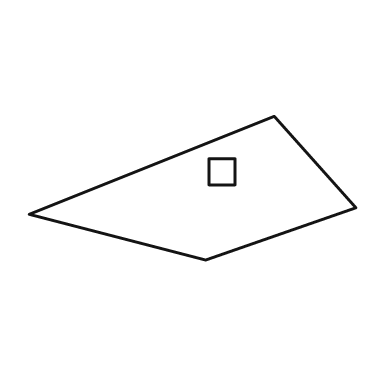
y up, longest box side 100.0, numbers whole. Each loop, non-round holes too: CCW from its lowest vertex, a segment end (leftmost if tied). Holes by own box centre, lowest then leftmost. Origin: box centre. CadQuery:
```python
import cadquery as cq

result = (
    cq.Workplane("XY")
    .moveTo(4.0, -22.0)
    .lineTo(50.0, -6.0)
    .lineTo(25.0, 22.0)
    .lineTo(-50.0, -8.0)
    .close()
    .moveTo(5.0, 1.0)
    .lineTo(13.0, 1.0)
    .lineTo(13.0, 9.0)
    .lineTo(5.0, 9.0)
    .close()
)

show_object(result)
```